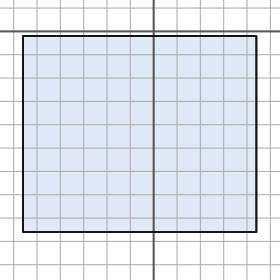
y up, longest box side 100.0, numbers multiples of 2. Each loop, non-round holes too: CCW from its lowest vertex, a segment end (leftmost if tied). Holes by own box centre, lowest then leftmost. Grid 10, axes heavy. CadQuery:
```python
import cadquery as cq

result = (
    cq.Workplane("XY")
    .moveTo(-56.0, -86.0)
    .lineTo(44.0, -86.0)
    .lineTo(44.0, -2.0)
    .lineTo(-56.0, -2.0)
    .close()
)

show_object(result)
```